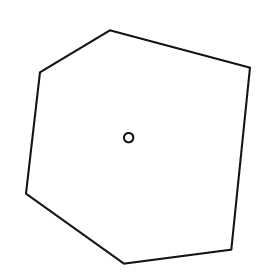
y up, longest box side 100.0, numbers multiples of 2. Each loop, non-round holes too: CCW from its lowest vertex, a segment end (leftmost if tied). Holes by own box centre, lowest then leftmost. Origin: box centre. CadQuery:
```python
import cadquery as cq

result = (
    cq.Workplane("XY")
    .moveTo(-6.0, -50.0)
    .lineTo(40.0, -44.0)
    .lineTo(48.0, 34.0)
    .lineTo(-12.0, 50.0)
    .lineTo(-42.0, 32.0)
    .lineTo(-48.0, -20.0)
    .close()
    .moveTo(-4.0, 4.0)
    .circle(2.0)
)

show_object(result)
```